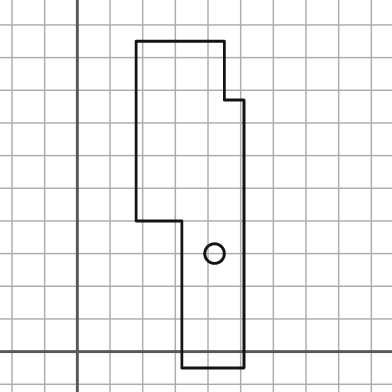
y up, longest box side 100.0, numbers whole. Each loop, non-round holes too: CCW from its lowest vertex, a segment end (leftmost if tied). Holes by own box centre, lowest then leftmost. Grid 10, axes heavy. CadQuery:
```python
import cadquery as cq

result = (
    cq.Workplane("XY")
    .moveTo(32.0, -5.0)
    .lineTo(51.0, -5.0)
    .lineTo(51.0, 77.0)
    .lineTo(45.0, 77.0)
    .lineTo(45.0, 95.0)
    .lineTo(18.0, 95.0)
    .lineTo(18.0, 40.0)
    .lineTo(32.0, 40.0)
    .close()
    .moveTo(42.0, 30.0)
    .circle(3.0)
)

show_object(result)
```